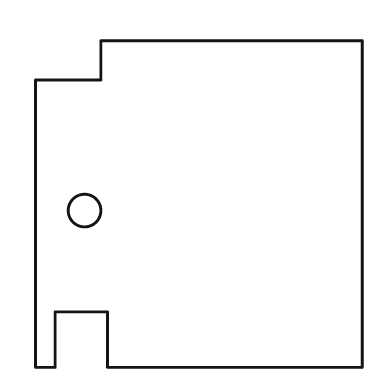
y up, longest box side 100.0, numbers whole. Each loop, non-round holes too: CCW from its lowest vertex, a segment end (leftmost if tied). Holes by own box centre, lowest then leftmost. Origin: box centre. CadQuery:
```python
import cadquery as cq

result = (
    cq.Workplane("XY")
    .moveTo(-50.0, -50.0)
    .lineTo(-44.0, -50.0)
    .lineTo(-44.0, -33.0)
    .lineTo(-28.0, -33.0)
    .lineTo(-28.0, -50.0)
    .lineTo(50.0, -50.0)
    .lineTo(50.0, 50.0)
    .lineTo(-30.0, 50.0)
    .lineTo(-30.0, 38.0)
    .lineTo(-50.0, 38.0)
    .close()
    .moveTo(-35.0, -2.0)
    .circle(5.0)
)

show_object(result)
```